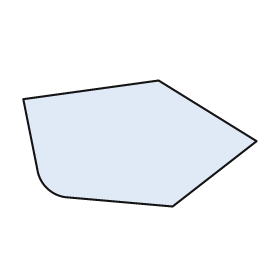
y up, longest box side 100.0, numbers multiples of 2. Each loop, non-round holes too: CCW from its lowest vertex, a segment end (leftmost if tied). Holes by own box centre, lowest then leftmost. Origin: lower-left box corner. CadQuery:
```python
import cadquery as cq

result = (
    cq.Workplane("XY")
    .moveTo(64.0, 0.0)
    .lineTo(100.0, 28.0)
    .lineTo(58.0, 54.0)
    .lineTo(0.0, 46.0)
    .lineTo(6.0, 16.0)
    .threePointArc((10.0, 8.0), (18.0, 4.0))
    .close()
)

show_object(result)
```